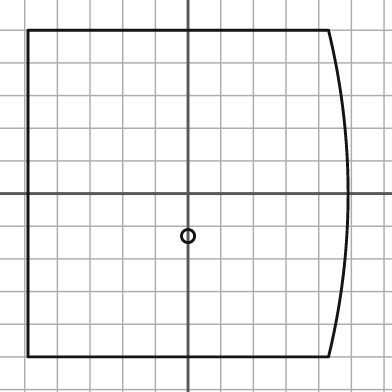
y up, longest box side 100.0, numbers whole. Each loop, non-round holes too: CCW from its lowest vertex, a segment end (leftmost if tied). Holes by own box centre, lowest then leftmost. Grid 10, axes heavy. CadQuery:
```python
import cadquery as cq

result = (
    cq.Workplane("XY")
    .moveTo(-49.0, -50.0)
    .lineTo(43.0, -50.0)
    .threePointArc((49.0, 0.0), (43.0, 50.0))
    .lineTo(-49.0, 50.0)
    .close()
    .moveTo(0.0, -13.0)
    .circle(2.0)
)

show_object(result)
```